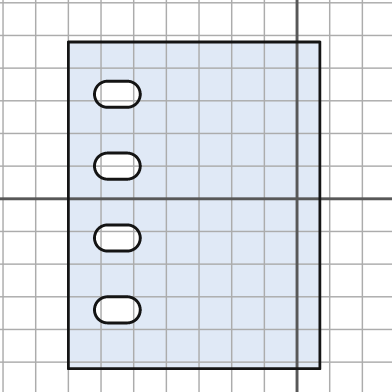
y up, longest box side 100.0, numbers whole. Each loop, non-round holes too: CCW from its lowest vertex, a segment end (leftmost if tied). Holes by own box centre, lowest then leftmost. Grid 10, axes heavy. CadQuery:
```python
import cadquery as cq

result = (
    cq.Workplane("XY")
    .moveTo(-70.0, -52.0)
    .lineTo(7.0, -52.0)
    .lineTo(7.0, 48.0)
    .lineTo(-70.0, 48.0)
    .close()
    .moveTo(-58.0, -38.0)
    .lineTo(-52.0, -38.0)
    .threePointArc((-48.0, -34.0), (-52.0, -30.0))
    .lineTo(-58.0, -30.0)
    .threePointArc((-62.0, -34.0), (-58.0, -38.0))
    .close()
    .moveTo(-58.0, -16.0)
    .lineTo(-52.0, -16.0)
    .threePointArc((-48.0, -12.0), (-52.0, -8.0))
    .lineTo(-58.0, -8.0)
    .threePointArc((-62.0, -12.0), (-58.0, -16.0))
    .close()
    .moveTo(-58.0, 6.0)
    .lineTo(-52.0, 6.0)
    .threePointArc((-48.0, 10.0), (-52.0, 14.0))
    .lineTo(-58.0, 14.0)
    .threePointArc((-62.0, 10.0), (-58.0, 6.0))
    .close()
    .moveTo(-58.0, 28.0)
    .lineTo(-52.0, 28.0)
    .threePointArc((-48.0, 32.0), (-52.0, 36.0))
    .lineTo(-58.0, 36.0)
    .threePointArc((-62.0, 32.0), (-58.0, 28.0))
    .close()
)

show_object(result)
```